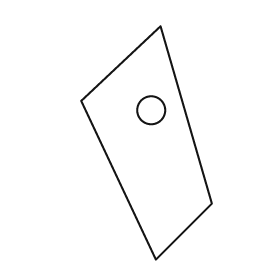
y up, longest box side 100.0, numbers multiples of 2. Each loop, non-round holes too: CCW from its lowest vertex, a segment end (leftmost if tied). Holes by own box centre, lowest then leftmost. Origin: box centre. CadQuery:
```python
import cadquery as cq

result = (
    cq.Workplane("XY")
    .moveTo(4.0, -50.0)
    .lineTo(28.0, -26.0)
    .lineTo(6.0, 50.0)
    .lineTo(-28.0, 18.0)
    .close()
    .moveTo(2.0, 14.0)
    .circle(6.0)
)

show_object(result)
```